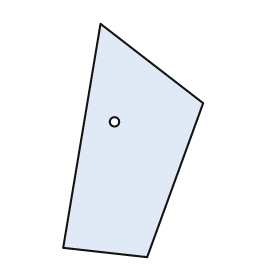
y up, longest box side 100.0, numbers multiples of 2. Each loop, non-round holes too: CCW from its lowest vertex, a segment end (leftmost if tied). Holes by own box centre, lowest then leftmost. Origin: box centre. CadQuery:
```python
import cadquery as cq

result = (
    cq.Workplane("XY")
    .moveTo(6.0, -50.0)
    .lineTo(30.0, 16.0)
    .lineTo(-14.0, 50.0)
    .lineTo(-30.0, -46.0)
    .close()
    .moveTo(-8.0, 8.0)
    .circle(2.0)
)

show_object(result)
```